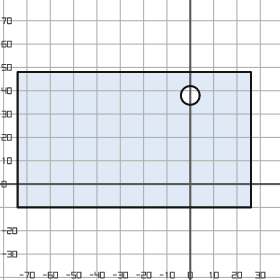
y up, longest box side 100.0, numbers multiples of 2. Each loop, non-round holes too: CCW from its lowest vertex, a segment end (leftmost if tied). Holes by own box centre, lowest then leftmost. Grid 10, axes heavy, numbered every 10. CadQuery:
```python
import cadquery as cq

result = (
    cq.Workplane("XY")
    .moveTo(-74.0, -10.0)
    .lineTo(26.0, -10.0)
    .lineTo(26.0, 48.0)
    .lineTo(-74.0, 48.0)
    .close()
    .moveTo(0.0, 38.0)
    .circle(4.0)
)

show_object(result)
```